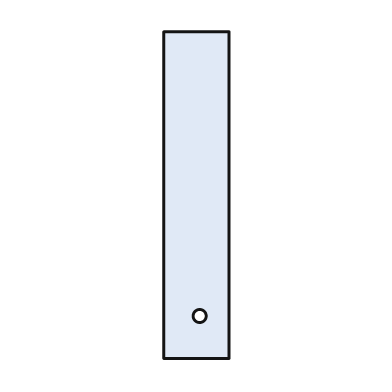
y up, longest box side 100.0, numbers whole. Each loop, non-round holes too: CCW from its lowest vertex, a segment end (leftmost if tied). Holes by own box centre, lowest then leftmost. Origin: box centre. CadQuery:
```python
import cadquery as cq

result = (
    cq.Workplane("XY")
    .moveTo(-10.0, -50.0)
    .lineTo(10.0, -50.0)
    .lineTo(10.0, 50.0)
    .lineTo(-10.0, 50.0)
    .close()
    .moveTo(1.0, -37.0)
    .circle(2.0)
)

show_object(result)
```